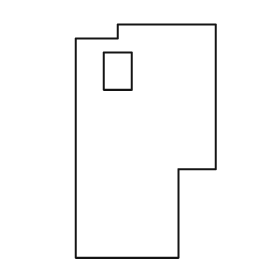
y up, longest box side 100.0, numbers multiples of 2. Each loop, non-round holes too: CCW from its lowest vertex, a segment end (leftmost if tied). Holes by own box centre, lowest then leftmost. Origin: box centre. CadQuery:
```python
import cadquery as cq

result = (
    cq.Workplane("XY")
    .moveTo(-30.0, -50.0)
    .lineTo(14.0, -50.0)
    .lineTo(14.0, -12.0)
    .lineTo(30.0, -12.0)
    .lineTo(30.0, 50.0)
    .lineTo(-12.0, 50.0)
    .lineTo(-12.0, 44.0)
    .lineTo(-30.0, 44.0)
    .close()
    .moveTo(-18.0, 22.0)
    .lineTo(-6.0, 22.0)
    .lineTo(-6.0, 38.0)
    .lineTo(-18.0, 38.0)
    .close()
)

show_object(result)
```